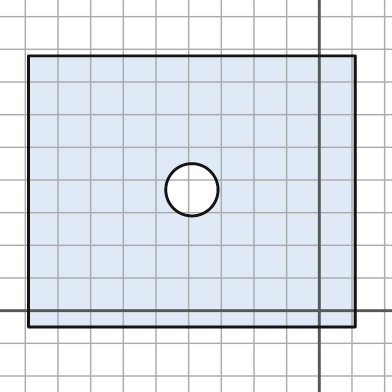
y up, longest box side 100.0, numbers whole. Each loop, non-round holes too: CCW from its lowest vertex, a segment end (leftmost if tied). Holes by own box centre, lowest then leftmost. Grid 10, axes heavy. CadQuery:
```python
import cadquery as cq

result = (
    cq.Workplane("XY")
    .moveTo(-89.0, -5.0)
    .lineTo(11.0, -5.0)
    .lineTo(11.0, 78.0)
    .lineTo(-89.0, 78.0)
    .close()
    .moveTo(-39.0, 37.0)
    .circle(8.0)
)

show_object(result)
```